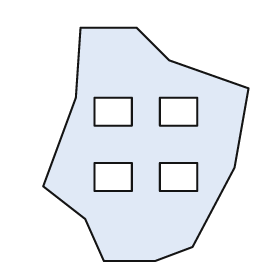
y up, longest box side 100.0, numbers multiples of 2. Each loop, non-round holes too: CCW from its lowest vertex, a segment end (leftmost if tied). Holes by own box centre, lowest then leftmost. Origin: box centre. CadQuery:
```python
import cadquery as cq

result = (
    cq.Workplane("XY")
    .moveTo(-18.0, -50.0)
    .lineTo(4.0, -50.0)
    .lineTo(20.0, -44.0)
    .lineTo(38.0, -10.0)
    .lineTo(44.0, 24.0)
    .lineTo(10.0, 36.0)
    .lineTo(-4.0, 50.0)
    .lineTo(-28.0, 50.0)
    .lineTo(-30.0, 20.0)
    .lineTo(-44.0, -18.0)
    .lineTo(-26.0, -32.0)
    .close()
    .moveTo(-22.0, -20.0)
    .lineTo(-6.0, -20.0)
    .lineTo(-6.0, -8.0)
    .lineTo(-22.0, -8.0)
    .close()
    .moveTo(6.0, -20.0)
    .lineTo(22.0, -20.0)
    .lineTo(22.0, -8.0)
    .lineTo(6.0, -8.0)
    .close()
    .moveTo(-22.0, 8.0)
    .lineTo(-6.0, 8.0)
    .lineTo(-6.0, 20.0)
    .lineTo(-22.0, 20.0)
    .close()
    .moveTo(6.0, 8.0)
    .lineTo(22.0, 8.0)
    .lineTo(22.0, 20.0)
    .lineTo(6.0, 20.0)
    .close()
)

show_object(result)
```